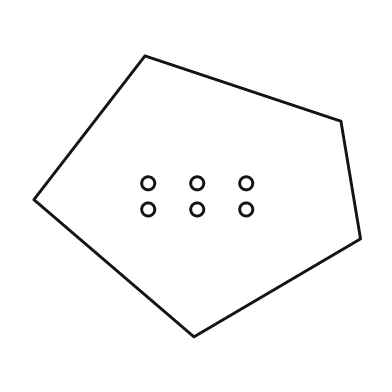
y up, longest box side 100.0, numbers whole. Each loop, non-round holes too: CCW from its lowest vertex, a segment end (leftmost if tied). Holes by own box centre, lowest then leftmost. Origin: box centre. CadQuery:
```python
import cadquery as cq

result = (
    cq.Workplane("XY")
    .moveTo(-1.0, -43.0)
    .lineTo(50.0, -13.0)
    .lineTo(44.0, 23.0)
    .lineTo(-16.0, 43.0)
    .lineTo(-50.0, -1.0)
    .close()
    .moveTo(-15.0, -4.0)
    .circle(2.0)
    .moveTo(0.0, -4.0)
    .circle(2.0)
    .moveTo(15.0, -4.0)
    .circle(2.0)
    .moveTo(-15.0, 4.0)
    .circle(2.0)
    .moveTo(0.0, 4.0)
    .circle(2.0)
    .moveTo(15.0, 4.0)
    .circle(2.0)
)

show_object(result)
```